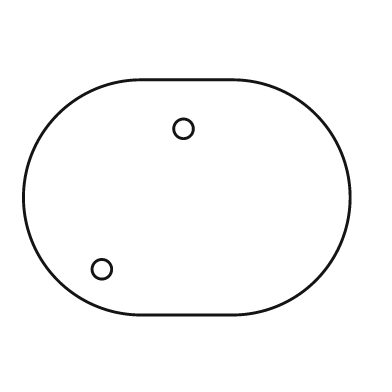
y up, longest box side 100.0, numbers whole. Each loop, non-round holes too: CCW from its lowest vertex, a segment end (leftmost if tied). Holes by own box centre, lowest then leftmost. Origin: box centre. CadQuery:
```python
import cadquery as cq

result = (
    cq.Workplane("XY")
    .moveTo(-14.0, -36.0)
    .lineTo(14.0, -36.0)
    .threePointArc((50.0, 0.0), (14.0, 36.0))
    .lineTo(-14.0, 36.0)
    .threePointArc((-50.0, 0.0), (-14.0, -36.0))
    .close()
    .moveTo(-26.0, -22.0)
    .circle(3.0)
    .moveTo(-1.0, 21.0)
    .circle(3.0)
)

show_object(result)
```